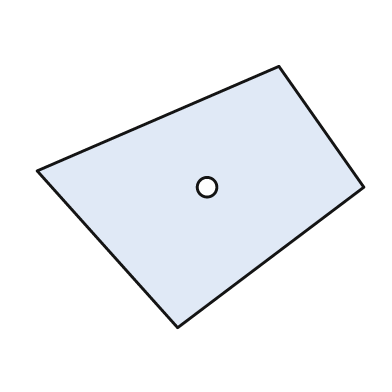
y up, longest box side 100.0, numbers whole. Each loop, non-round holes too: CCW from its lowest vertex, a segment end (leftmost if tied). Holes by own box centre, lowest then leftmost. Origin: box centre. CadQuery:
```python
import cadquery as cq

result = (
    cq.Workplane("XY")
    .moveTo(-7.0, -40.0)
    .lineTo(50.0, 3.0)
    .lineTo(24.0, 40.0)
    .lineTo(-50.0, 8.0)
    .close()
    .moveTo(2.0, 3.0)
    .circle(3.0)
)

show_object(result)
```